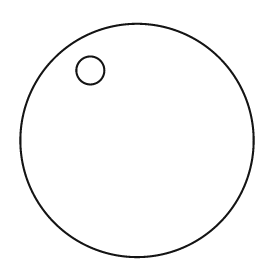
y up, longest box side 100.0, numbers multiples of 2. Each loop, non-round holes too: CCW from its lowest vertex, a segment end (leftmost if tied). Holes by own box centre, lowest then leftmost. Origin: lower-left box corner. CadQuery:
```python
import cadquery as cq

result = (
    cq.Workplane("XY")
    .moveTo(50.0, 50.0)
    .circle(50.0)
    .moveTo(30.0, 80.0)
    .circle(6.0)
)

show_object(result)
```